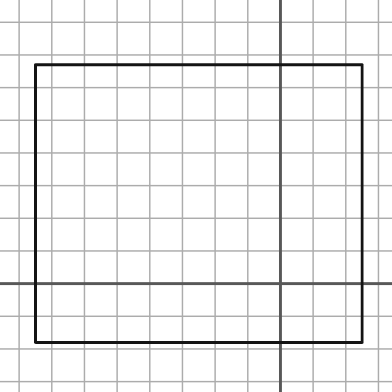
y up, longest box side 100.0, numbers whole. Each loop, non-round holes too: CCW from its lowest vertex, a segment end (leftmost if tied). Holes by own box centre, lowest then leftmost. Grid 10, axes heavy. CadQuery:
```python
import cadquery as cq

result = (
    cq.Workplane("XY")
    .moveTo(-75.0, -18.0)
    .lineTo(25.0, -18.0)
    .lineTo(25.0, 67.0)
    .lineTo(-75.0, 67.0)
    .close()
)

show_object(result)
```